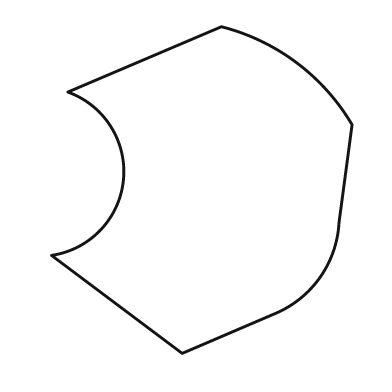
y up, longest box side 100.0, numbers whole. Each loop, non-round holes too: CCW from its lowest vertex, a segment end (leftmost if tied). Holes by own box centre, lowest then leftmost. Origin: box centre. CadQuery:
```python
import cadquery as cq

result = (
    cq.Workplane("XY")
    .moveTo(-6.0, -50.0)
    .lineTo(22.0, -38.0)
    .threePointArc((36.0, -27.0), (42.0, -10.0))
    .lineTo(46.0, 20.0)
    .threePointArc((29.0, 39.0), (6.0, 50.0))
    .lineTo(-41.0, 30.0)
    .threePointArc((-24.0, 3.0), (-46.0, -20.0))
    .close()
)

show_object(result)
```